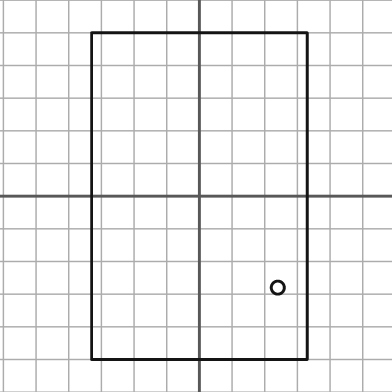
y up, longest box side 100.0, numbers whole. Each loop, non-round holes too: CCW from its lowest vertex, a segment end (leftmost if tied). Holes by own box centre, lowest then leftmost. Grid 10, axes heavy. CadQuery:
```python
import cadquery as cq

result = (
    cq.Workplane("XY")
    .moveTo(-33.0, -50.0)
    .lineTo(33.0, -50.0)
    .lineTo(33.0, 50.0)
    .lineTo(-33.0, 50.0)
    .close()
    .moveTo(24.0, -28.0)
    .circle(2.0)
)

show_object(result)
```